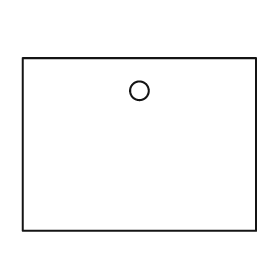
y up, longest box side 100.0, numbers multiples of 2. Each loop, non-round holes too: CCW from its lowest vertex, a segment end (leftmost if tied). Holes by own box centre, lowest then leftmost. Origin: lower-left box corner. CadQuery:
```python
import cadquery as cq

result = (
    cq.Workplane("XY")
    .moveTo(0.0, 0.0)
    .lineTo(100.0, 0.0)
    .lineTo(100.0, 74.0)
    .lineTo(0.0, 74.0)
    .close()
    .moveTo(50.0, 60.0)
    .circle(4.0)
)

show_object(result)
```